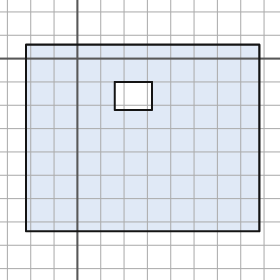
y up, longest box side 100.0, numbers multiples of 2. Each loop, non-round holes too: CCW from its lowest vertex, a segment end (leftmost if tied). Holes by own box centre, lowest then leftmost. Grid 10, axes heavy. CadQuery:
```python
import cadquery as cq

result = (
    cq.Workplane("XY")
    .moveTo(-22.0, -74.0)
    .lineTo(78.0, -74.0)
    .lineTo(78.0, 6.0)
    .lineTo(-22.0, 6.0)
    .close()
    .moveTo(16.0, -22.0)
    .lineTo(32.0, -22.0)
    .lineTo(32.0, -10.0)
    .lineTo(16.0, -10.0)
    .close()
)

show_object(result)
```